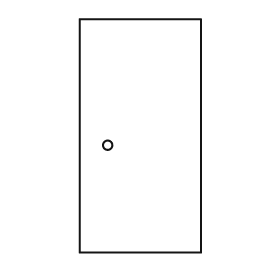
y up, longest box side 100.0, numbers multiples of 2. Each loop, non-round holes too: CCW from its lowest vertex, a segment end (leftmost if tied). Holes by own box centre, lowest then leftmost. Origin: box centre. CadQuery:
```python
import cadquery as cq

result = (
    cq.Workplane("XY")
    .moveTo(-26.0, -50.0)
    .lineTo(26.0, -50.0)
    .lineTo(26.0, 50.0)
    .lineTo(-26.0, 50.0)
    .close()
    .moveTo(-14.0, -4.0)
    .circle(2.0)
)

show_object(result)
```